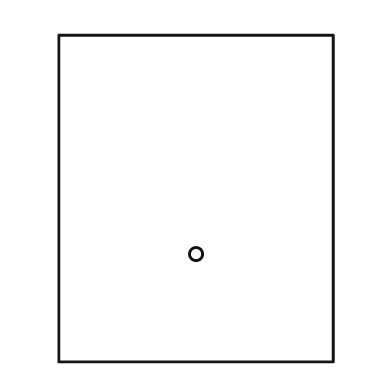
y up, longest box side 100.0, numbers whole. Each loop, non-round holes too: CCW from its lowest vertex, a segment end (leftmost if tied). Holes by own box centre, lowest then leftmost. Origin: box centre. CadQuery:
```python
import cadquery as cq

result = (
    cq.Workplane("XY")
    .moveTo(-42.0, -50.0)
    .lineTo(42.0, -50.0)
    .lineTo(42.0, 50.0)
    .lineTo(-42.0, 50.0)
    .close()
    .moveTo(0.0, -17.0)
    .circle(2.0)
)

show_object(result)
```